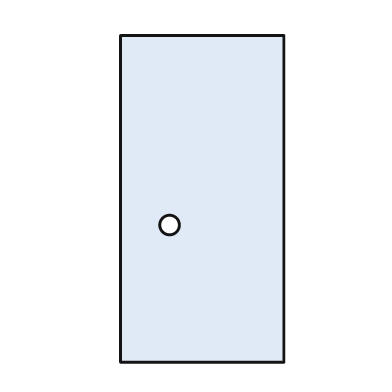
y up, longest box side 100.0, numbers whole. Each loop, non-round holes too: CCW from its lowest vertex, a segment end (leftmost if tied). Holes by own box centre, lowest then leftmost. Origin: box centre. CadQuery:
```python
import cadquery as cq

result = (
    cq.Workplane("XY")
    .moveTo(-25.0, -50.0)
    .lineTo(25.0, -50.0)
    .lineTo(25.0, 50.0)
    .lineTo(-25.0, 50.0)
    .close()
    .moveTo(-10.0, -8.0)
    .circle(3.0)
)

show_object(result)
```